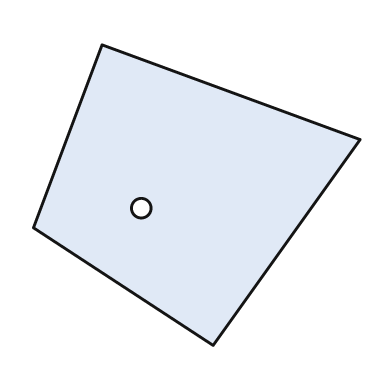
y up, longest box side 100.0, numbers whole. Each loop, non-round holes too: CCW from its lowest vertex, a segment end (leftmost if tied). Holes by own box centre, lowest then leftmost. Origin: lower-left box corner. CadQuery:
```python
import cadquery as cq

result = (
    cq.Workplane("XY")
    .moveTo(55.0, 0.0)
    .lineTo(100.0, 63.0)
    .lineTo(21.0, 92.0)
    .lineTo(0.0, 36.0)
    .close()
    .moveTo(33.0, 42.0)
    .circle(3.0)
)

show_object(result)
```